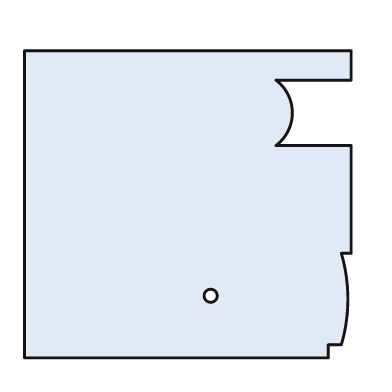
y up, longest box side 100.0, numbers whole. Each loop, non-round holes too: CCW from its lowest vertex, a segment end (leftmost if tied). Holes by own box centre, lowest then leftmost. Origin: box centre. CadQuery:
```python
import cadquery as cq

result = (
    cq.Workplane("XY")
    .moveTo(-50.0, -47.0)
    .lineTo(43.0, -47.0)
    .lineTo(43.0, -43.0)
    .lineTo(47.0, -43.0)
    .threePointArc((49.0, -29.0), (47.0, -15.0))
    .lineTo(50.0, -15.0)
    .lineTo(50.0, 18.0)
    .lineTo(27.0, 18.0)
    .threePointArc((32.0, 28.0), (27.0, 38.0))
    .lineTo(50.0, 38.0)
    .lineTo(50.0, 47.0)
    .lineTo(-50.0, 47.0)
    .close()
    .moveTo(7.0, -28.0)
    .circle(2.0)
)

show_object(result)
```